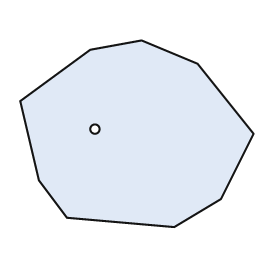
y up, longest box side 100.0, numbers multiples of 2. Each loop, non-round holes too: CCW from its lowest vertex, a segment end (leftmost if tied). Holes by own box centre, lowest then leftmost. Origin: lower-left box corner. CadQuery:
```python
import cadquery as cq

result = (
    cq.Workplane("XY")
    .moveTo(66.0, 0.0)
    .lineTo(86.0, 12.0)
    .lineTo(100.0, 40.0)
    .lineTo(76.0, 70.0)
    .lineTo(52.0, 80.0)
    .lineTo(30.0, 76.0)
    .lineTo(0.0, 54.0)
    .lineTo(8.0, 20.0)
    .lineTo(20.0, 4.0)
    .close()
    .moveTo(32.0, 42.0)
    .circle(2.0)
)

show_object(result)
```